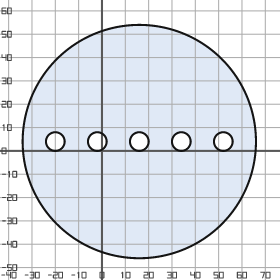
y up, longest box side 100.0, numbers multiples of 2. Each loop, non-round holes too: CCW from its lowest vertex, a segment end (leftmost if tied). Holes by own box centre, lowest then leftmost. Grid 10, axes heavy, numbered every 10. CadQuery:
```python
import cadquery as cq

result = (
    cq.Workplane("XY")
    .moveTo(16.0, 4.0)
    .circle(50.0)
    .moveTo(-20.0, 4.0)
    .circle(4.0)
    .moveTo(-2.0, 4.0)
    .circle(4.0)
    .moveTo(16.0, 4.0)
    .circle(4.0)
    .moveTo(34.0, 4.0)
    .circle(4.0)
    .moveTo(52.0, 4.0)
    .circle(4.0)
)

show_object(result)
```